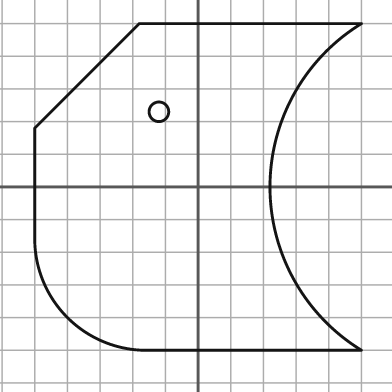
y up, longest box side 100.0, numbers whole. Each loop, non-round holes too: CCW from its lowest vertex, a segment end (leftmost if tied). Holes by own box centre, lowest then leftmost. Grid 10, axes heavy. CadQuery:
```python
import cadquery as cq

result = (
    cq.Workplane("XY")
    .moveTo(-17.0, -50.0)
    .lineTo(50.0, -50.0)
    .threePointArc((22.0, 0.0), (50.0, 50.0))
    .lineTo(-18.0, 50.0)
    .lineTo(-50.0, 18.0)
    .lineTo(-50.0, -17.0)
    .threePointArc((-40.0, -40.0), (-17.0, -50.0))
    .close()
    .moveTo(-12.0, 23.0)
    .circle(3.0)
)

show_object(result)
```